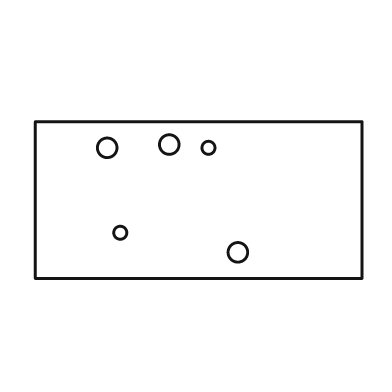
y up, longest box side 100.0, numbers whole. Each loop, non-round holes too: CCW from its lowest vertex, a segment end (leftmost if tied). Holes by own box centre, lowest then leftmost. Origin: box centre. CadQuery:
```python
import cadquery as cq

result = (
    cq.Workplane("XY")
    .moveTo(-50.0, -24.0)
    .lineTo(50.0, -24.0)
    .lineTo(50.0, 24.0)
    .lineTo(-50.0, 24.0)
    .close()
    .moveTo(12.0, -16.0)
    .circle(3.0)
    .moveTo(-24.0, -10.0)
    .circle(2.0)
    .moveTo(-28.0, 16.0)
    .circle(3.0)
    .moveTo(3.0, 16.0)
    .circle(2.0)
    .moveTo(-9.0, 17.0)
    .circle(3.0)
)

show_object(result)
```